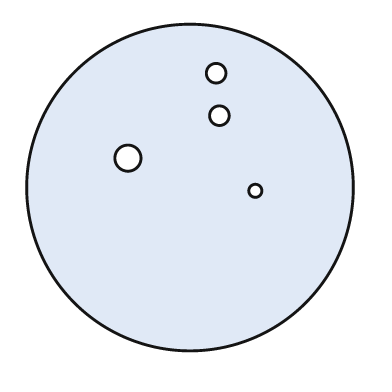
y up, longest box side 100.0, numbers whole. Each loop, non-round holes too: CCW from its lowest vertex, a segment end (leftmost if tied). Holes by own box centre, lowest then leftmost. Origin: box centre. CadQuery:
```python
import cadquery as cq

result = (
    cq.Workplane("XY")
    .moveTo(0.0, 0.0)
    .circle(50.0)
    .moveTo(20.0, -1.0)
    .circle(2.0)
    .moveTo(-19.0, 9.0)
    .circle(4.0)
    .moveTo(9.0, 22.0)
    .circle(3.0)
    .moveTo(8.0, 35.0)
    .circle(3.0)
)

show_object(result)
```